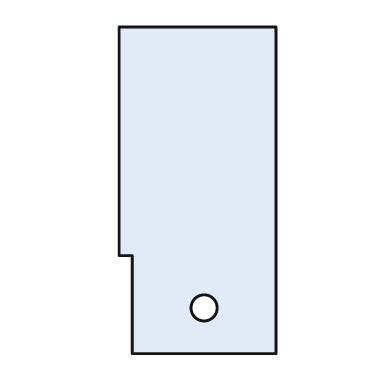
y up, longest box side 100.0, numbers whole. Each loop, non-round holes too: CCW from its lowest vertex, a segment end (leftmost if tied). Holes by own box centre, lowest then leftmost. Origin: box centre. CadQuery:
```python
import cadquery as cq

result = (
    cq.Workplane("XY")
    .moveTo(-20.0, -50.0)
    .lineTo(24.0, -50.0)
    .lineTo(24.0, 50.0)
    .lineTo(-24.0, 50.0)
    .lineTo(-24.0, -20.0)
    .lineTo(-20.0, -20.0)
    .close()
    .moveTo(2.0, -36.0)
    .circle(4.0)
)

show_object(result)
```